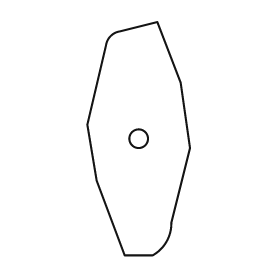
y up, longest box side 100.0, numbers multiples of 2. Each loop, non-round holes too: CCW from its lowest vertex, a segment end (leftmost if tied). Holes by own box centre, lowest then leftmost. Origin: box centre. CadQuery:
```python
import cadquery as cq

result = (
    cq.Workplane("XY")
    .moveTo(-6.0, -50.0)
    .lineTo(6.0, -50.0)
    .threePointArc((12.0, -44.0), (14.0, -36.0))
    .lineTo(22.0, -4.0)
    .lineTo(18.0, 24.0)
    .lineTo(8.0, 50.0)
    .lineTo(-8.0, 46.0)
    .threePointArc((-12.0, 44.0), (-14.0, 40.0))
    .lineTo(-22.0, 6.0)
    .lineTo(-18.0, -18.0)
    .close()
    .moveTo(0.0, 0.0)
    .circle(4.0)
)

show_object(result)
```